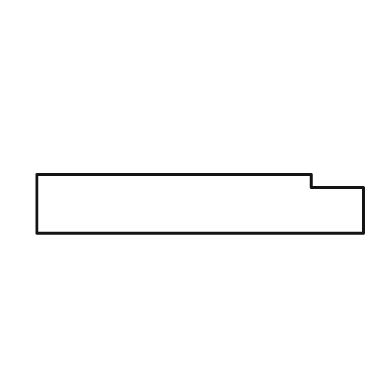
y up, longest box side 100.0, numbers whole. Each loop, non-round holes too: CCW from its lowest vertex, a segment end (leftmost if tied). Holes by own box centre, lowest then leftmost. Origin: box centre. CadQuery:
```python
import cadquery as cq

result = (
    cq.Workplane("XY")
    .moveTo(-50.0, -9.0)
    .lineTo(50.0, -9.0)
    .lineTo(50.0, 5.0)
    .lineTo(34.0, 5.0)
    .lineTo(34.0, 9.0)
    .lineTo(-50.0, 9.0)
    .close()
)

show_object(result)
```